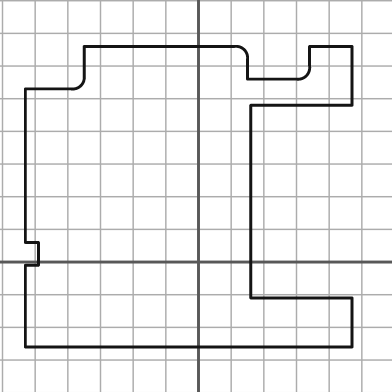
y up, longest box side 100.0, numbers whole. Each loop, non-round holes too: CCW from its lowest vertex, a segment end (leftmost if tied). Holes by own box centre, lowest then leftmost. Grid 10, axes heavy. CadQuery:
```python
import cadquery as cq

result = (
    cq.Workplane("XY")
    .moveTo(-53.0, -26.0)
    .lineTo(47.0, -26.0)
    .lineTo(47.0, -11.0)
    .lineTo(16.0, -11.0)
    .lineTo(16.0, 48.0)
    .lineTo(47.0, 48.0)
    .lineTo(47.0, 66.0)
    .lineTo(34.0, 66.0)
    .lineTo(34.0, 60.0)
    .threePointArc((33.0, 57.0), (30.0, 56.0))
    .lineTo(15.0, 56.0)
    .lineTo(15.0, 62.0)
    .threePointArc((14.0, 65.0), (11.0, 66.0))
    .lineTo(-35.0, 66.0)
    .lineTo(-35.0, 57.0)
    .threePointArc((-36.0, 54.0), (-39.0, 53.0))
    .lineTo(-53.0, 53.0)
    .lineTo(-53.0, 6.0)
    .lineTo(-49.0, 6.0)
    .lineTo(-49.0, -1.0)
    .lineTo(-53.0, -1.0)
    .close()
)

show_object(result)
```